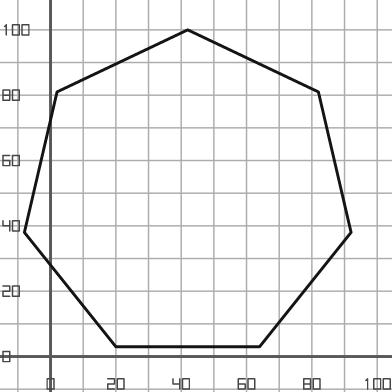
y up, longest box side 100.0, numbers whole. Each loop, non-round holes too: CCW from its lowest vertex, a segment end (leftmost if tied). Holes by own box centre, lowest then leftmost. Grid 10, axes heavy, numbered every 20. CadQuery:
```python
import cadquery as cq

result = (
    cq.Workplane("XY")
    .moveTo(20.0, 3.0)
    .lineTo(64.0, 3.0)
    .lineTo(92.0, 38.0)
    .lineTo(82.0, 81.0)
    .lineTo(42.0, 100.0)
    .lineTo(2.0, 81.0)
    .lineTo(-8.0, 38.0)
    .close()
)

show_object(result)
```